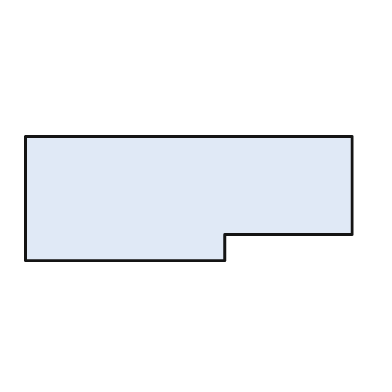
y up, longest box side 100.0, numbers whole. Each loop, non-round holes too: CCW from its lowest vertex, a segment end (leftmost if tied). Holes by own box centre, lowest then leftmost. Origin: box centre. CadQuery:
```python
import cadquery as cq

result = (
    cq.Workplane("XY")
    .moveTo(-50.0, -19.0)
    .lineTo(11.0, -19.0)
    .lineTo(11.0, -11.0)
    .lineTo(50.0, -11.0)
    .lineTo(50.0, 19.0)
    .lineTo(-50.0, 19.0)
    .close()
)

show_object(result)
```